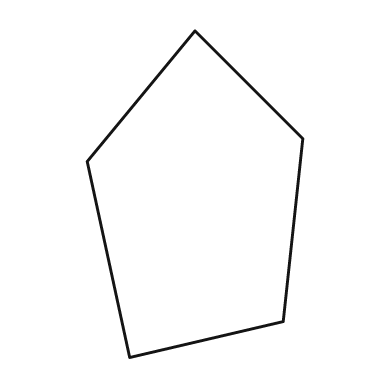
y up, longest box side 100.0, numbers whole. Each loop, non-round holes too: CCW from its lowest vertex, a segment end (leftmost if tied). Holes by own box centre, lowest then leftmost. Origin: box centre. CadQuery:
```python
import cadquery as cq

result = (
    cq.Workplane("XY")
    .moveTo(-20.0, -50.0)
    .lineTo(27.0, -39.0)
    .lineTo(33.0, 17.0)
    .lineTo(0.0, 50.0)
    .lineTo(-33.0, 10.0)
    .close()
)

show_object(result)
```